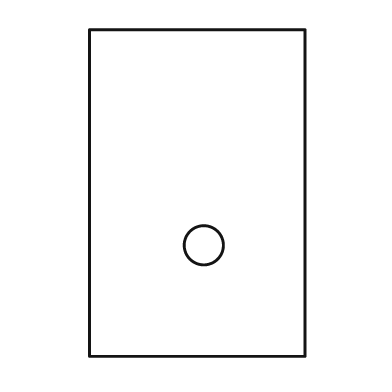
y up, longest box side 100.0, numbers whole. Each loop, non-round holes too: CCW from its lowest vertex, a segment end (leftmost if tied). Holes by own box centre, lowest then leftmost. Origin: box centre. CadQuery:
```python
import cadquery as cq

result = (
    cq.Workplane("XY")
    .moveTo(-33.0, -50.0)
    .lineTo(33.0, -50.0)
    .lineTo(33.0, 50.0)
    .lineTo(-33.0, 50.0)
    .close()
    .moveTo(2.0, -16.0)
    .circle(6.0)
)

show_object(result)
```